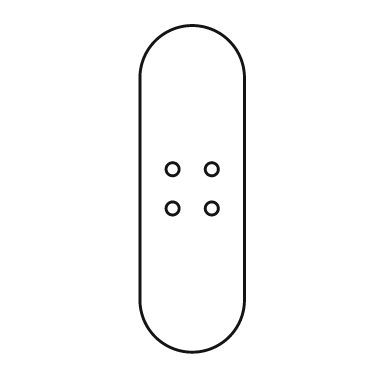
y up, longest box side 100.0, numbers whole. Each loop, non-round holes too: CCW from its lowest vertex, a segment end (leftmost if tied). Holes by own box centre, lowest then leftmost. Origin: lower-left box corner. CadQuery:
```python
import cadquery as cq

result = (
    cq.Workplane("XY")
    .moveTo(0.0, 16.0)
    .threePointArc((16.0, 0.0), (32.0, 16.0))
    .lineTo(32.0, 84.0)
    .threePointArc((16.0, 100.0), (0.0, 84.0))
    .close()
    .moveTo(10.0, 44.0)
    .circle(2.0)
    .moveTo(22.0, 44.0)
    .circle(2.0)
    .moveTo(10.0, 56.0)
    .circle(2.0)
    .moveTo(22.0, 56.0)
    .circle(2.0)
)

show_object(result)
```